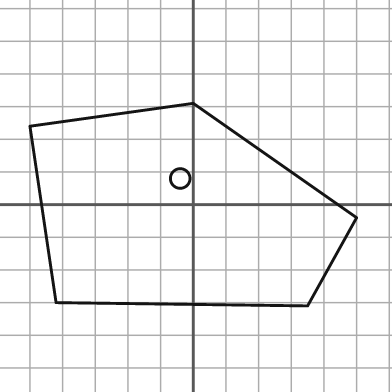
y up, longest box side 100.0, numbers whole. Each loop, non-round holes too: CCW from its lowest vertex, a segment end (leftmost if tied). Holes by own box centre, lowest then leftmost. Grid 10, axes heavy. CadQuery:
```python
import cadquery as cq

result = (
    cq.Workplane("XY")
    .moveTo(35.0, -31.0)
    .lineTo(50.0, -4.0)
    .lineTo(0.0, 31.0)
    .lineTo(-50.0, 24.0)
    .lineTo(-42.0, -30.0)
    .close()
    .moveTo(-4.0, 8.0)
    .circle(3.0)
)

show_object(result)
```